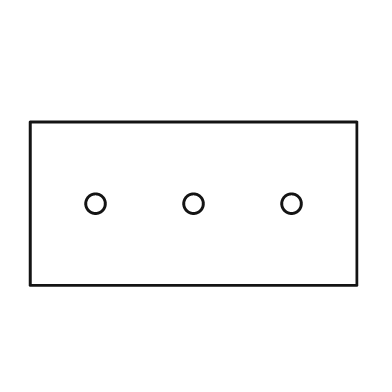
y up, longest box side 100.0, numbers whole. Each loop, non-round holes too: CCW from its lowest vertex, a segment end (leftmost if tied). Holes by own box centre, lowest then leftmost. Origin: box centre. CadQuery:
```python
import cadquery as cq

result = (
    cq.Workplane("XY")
    .moveTo(-50.0, -25.0)
    .lineTo(50.0, -25.0)
    .lineTo(50.0, 25.0)
    .lineTo(-50.0, 25.0)
    .close()
    .moveTo(-30.0, 0.0)
    .circle(3.0)
    .moveTo(0.0, 0.0)
    .circle(3.0)
    .moveTo(30.0, 0.0)
    .circle(3.0)
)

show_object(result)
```